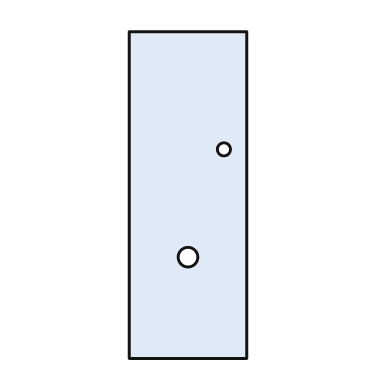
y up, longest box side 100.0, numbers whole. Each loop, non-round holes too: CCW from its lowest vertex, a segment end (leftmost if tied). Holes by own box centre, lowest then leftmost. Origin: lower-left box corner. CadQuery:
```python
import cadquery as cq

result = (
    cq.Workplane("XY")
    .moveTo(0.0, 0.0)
    .lineTo(36.0, 0.0)
    .lineTo(36.0, 100.0)
    .lineTo(0.0, 100.0)
    .close()
    .moveTo(18.0, 31.0)
    .circle(3.0)
    .moveTo(29.0, 64.0)
    .circle(2.0)
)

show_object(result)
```